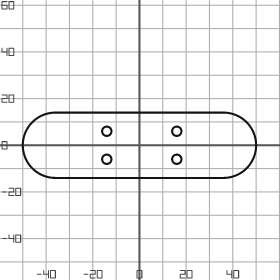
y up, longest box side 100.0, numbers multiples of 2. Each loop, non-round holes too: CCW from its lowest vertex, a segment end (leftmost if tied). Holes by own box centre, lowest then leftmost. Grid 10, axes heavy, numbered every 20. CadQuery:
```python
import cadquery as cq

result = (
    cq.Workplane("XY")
    .moveTo(-36.0, -14.0)
    .lineTo(36.0, -14.0)
    .threePointArc((50.0, 0.0), (36.0, 14.0))
    .lineTo(-36.0, 14.0)
    .threePointArc((-50.0, 0.0), (-36.0, -14.0))
    .close()
    .moveTo(-14.0, -6.0)
    .circle(2.0)
    .moveTo(16.0, -6.0)
    .circle(2.0)
    .moveTo(-14.0, 6.0)
    .circle(2.0)
    .moveTo(16.0, 6.0)
    .circle(2.0)
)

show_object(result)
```